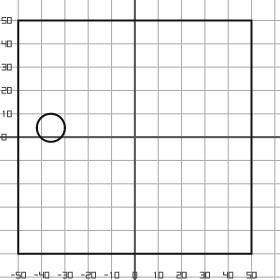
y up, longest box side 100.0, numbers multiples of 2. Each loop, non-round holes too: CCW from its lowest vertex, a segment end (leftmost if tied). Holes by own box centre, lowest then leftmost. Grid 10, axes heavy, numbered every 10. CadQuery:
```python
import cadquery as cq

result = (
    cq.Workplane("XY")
    .moveTo(-50.0, -50.0)
    .lineTo(50.0, -50.0)
    .lineTo(50.0, 50.0)
    .lineTo(-50.0, 50.0)
    .close()
    .moveTo(-36.0, 4.0)
    .circle(6.0)
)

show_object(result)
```